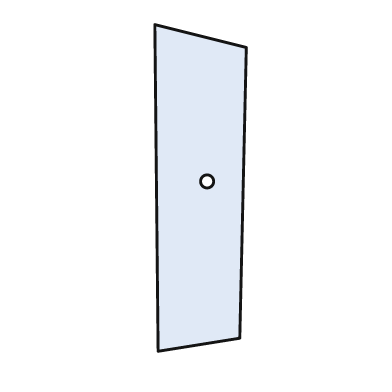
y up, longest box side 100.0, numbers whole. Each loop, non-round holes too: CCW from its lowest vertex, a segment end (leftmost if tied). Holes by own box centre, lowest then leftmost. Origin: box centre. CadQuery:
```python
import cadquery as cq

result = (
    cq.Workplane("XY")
    .moveTo(-13.0, -50.0)
    .lineTo(12.0, -46.0)
    .lineTo(14.0, 43.0)
    .lineTo(-14.0, 50.0)
    .close()
    .moveTo(2.0, 2.0)
    .circle(2.0)
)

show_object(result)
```